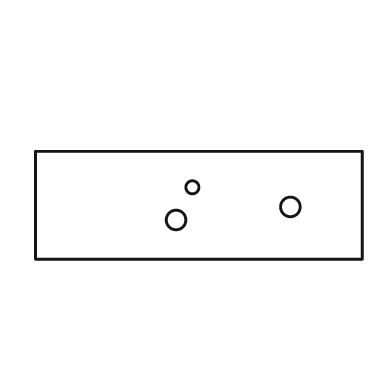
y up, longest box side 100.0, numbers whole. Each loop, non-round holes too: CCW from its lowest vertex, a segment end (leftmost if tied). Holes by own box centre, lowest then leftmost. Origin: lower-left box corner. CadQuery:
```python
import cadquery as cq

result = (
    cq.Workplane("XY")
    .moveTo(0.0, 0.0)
    .lineTo(100.0, 0.0)
    .lineTo(100.0, 33.0)
    .lineTo(0.0, 33.0)
    .close()
    .moveTo(43.0, 12.0)
    .circle(3.0)
    .moveTo(78.0, 16.0)
    .circle(3.0)
    .moveTo(48.0, 22.0)
    .circle(2.0)
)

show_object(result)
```